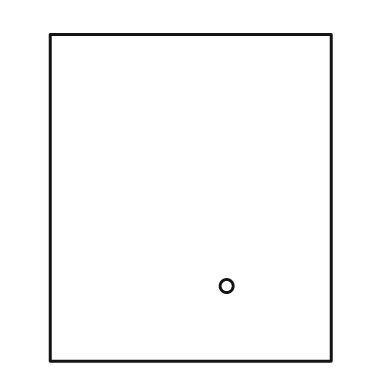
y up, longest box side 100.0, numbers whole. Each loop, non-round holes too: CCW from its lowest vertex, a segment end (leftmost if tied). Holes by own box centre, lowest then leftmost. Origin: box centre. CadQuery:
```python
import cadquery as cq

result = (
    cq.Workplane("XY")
    .moveTo(-43.0, -50.0)
    .lineTo(43.0, -50.0)
    .lineTo(43.0, 50.0)
    .lineTo(-43.0, 50.0)
    .close()
    .moveTo(11.0, -27.0)
    .circle(2.0)
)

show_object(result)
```